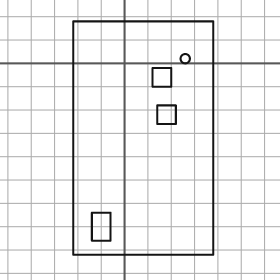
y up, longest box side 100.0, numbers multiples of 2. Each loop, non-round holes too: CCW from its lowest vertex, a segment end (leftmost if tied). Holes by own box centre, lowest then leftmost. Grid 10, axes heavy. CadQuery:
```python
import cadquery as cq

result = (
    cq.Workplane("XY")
    .moveTo(-22.0, -82.0)
    .lineTo(38.0, -82.0)
    .lineTo(38.0, 18.0)
    .lineTo(-22.0, 18.0)
    .close()
    .moveTo(-14.0, -76.0)
    .lineTo(-6.0, -76.0)
    .lineTo(-6.0, -64.0)
    .lineTo(-14.0, -64.0)
    .close()
    .moveTo(14.0, -26.0)
    .lineTo(22.0, -26.0)
    .lineTo(22.0, -18.0)
    .lineTo(14.0, -18.0)
    .close()
    .moveTo(12.0, -10.0)
    .lineTo(20.0, -10.0)
    .lineTo(20.0, -2.0)
    .lineTo(12.0, -2.0)
    .close()
    .moveTo(26.0, 2.0)
    .circle(2.0)
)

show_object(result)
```